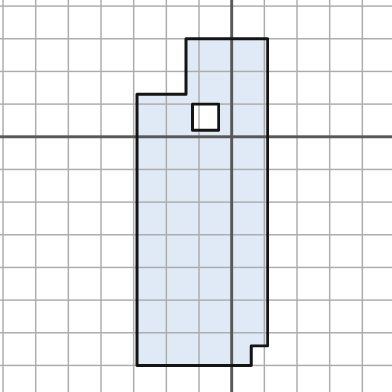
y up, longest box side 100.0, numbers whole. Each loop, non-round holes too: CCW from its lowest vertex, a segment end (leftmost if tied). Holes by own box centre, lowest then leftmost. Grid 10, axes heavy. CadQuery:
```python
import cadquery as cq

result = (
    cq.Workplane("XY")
    .moveTo(-29.0, -70.0)
    .lineTo(6.0, -70.0)
    .lineTo(6.0, -64.0)
    .lineTo(11.0, -64.0)
    .lineTo(11.0, 30.0)
    .lineTo(-14.0, 30.0)
    .lineTo(-14.0, 13.0)
    .lineTo(-29.0, 13.0)
    .close()
    .moveTo(-12.0, 2.0)
    .lineTo(-4.0, 2.0)
    .lineTo(-4.0, 10.0)
    .lineTo(-12.0, 10.0)
    .close()
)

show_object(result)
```